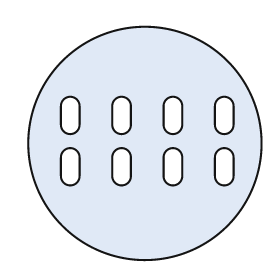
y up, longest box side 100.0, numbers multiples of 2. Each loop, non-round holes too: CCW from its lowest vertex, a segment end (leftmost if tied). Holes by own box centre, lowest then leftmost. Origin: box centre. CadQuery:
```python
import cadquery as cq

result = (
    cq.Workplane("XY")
    .moveTo(0.0, 0.0)
    .circle(50.0)
    .moveTo(-36.0, -14.0)
    .threePointArc((-32.0, -18.0), (-28.0, -14.0))
    .lineTo(-28.0, -6.0)
    .threePointArc((-32.0, -2.0), (-36.0, -6.0))
    .close()
    .moveTo(-14.0, -14.0)
    .threePointArc((-10.0, -18.0), (-6.0, -14.0))
    .lineTo(-6.0, -6.0)
    .threePointArc((-10.0, -2.0), (-14.0, -6.0))
    .close()
    .moveTo(8.0, -14.0)
    .threePointArc((12.0, -18.0), (16.0, -14.0))
    .lineTo(16.0, -6.0)
    .threePointArc((12.0, -2.0), (8.0, -6.0))
    .close()
    .moveTo(30.0, -14.0)
    .threePointArc((34.0, -18.0), (38.0, -14.0))
    .lineTo(38.0, -6.0)
    .threePointArc((34.0, -2.0), (30.0, -6.0))
    .close()
    .moveTo(-36.0, 8.0)
    .threePointArc((-32.0, 4.0), (-28.0, 8.0))
    .lineTo(-28.0, 16.0)
    .threePointArc((-32.0, 20.0), (-36.0, 16.0))
    .close()
    .moveTo(-14.0, 8.0)
    .threePointArc((-10.0, 4.0), (-6.0, 8.0))
    .lineTo(-6.0, 16.0)
    .threePointArc((-10.0, 20.0), (-14.0, 16.0))
    .close()
    .moveTo(8.0, 8.0)
    .threePointArc((12.0, 4.0), (16.0, 8.0))
    .lineTo(16.0, 16.0)
    .threePointArc((12.0, 20.0), (8.0, 16.0))
    .close()
    .moveTo(30.0, 8.0)
    .threePointArc((34.0, 4.0), (38.0, 8.0))
    .lineTo(38.0, 16.0)
    .threePointArc((34.0, 20.0), (30.0, 16.0))
    .close()
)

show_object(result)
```